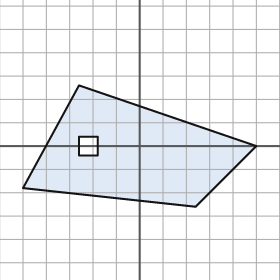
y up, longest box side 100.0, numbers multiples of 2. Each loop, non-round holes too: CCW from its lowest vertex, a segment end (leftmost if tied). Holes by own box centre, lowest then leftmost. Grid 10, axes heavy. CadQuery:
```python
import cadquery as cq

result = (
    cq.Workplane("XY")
    .moveTo(24.0, -26.0)
    .lineTo(50.0, 0.0)
    .lineTo(-26.0, 26.0)
    .lineTo(-50.0, -18.0)
    .close()
    .moveTo(-26.0, -4.0)
    .lineTo(-18.0, -4.0)
    .lineTo(-18.0, 4.0)
    .lineTo(-26.0, 4.0)
    .close()
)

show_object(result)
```